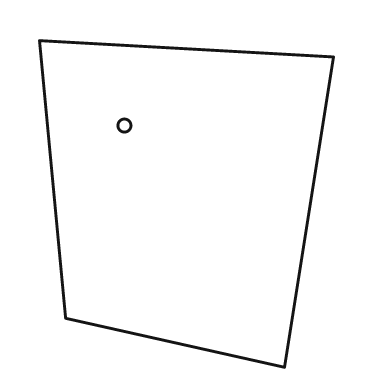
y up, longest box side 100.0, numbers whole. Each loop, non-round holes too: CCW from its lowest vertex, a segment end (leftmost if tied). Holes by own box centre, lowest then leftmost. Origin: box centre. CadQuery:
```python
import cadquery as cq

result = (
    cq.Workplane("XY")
    .moveTo(30.0, -50.0)
    .lineTo(45.0, 45.0)
    .lineTo(-45.0, 50.0)
    .lineTo(-37.0, -35.0)
    .close()
    .moveTo(-19.0, 24.0)
    .circle(2.0)
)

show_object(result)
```